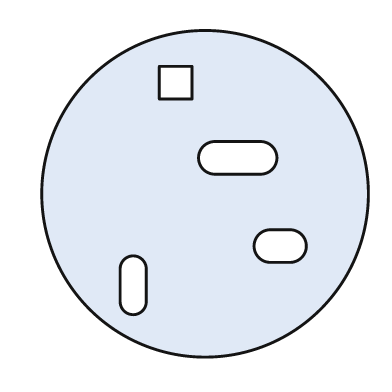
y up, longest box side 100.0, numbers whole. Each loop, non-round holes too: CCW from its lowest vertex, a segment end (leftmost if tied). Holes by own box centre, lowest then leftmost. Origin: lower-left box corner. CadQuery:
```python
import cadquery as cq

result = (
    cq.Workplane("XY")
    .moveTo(50.0, 50.0)
    .circle(50.0)
    .moveTo(24.0, 17.0)
    .threePointArc((28.0, 13.0), (32.0, 17.0))
    .lineTo(32.0, 27.0)
    .threePointArc((28.0, 31.0), (24.0, 27.0))
    .close()
    .moveTo(70.0, 29.0)
    .lineTo(76.0, 29.0)
    .threePointArc((81.0, 34.0), (76.0, 39.0))
    .lineTo(70.0, 39.0)
    .threePointArc((65.0, 34.0), (70.0, 29.0))
    .close()
    .moveTo(53.0, 56.0)
    .lineTo(67.0, 56.0)
    .threePointArc((72.0, 61.0), (67.0, 66.0))
    .lineTo(53.0, 66.0)
    .threePointArc((48.0, 61.0), (53.0, 56.0))
    .close()
    .moveTo(36.0, 79.0)
    .lineTo(46.0, 79.0)
    .lineTo(46.0, 89.0)
    .lineTo(36.0, 89.0)
    .close()
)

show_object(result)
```